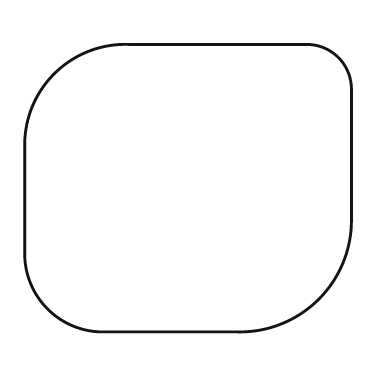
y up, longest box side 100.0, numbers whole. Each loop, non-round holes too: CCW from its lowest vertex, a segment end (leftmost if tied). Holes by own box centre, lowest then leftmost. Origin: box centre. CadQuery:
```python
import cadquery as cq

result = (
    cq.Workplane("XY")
    .moveTo(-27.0, -44.0)
    .lineTo(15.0, -44.0)
    .threePointArc((40.0, -34.0), (50.0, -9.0))
    .lineTo(50.0, 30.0)
    .threePointArc((46.0, 40.0), (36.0, 44.0))
    .lineTo(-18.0, 44.0)
    .threePointArc((-41.0, 35.0), (-50.0, 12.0))
    .lineTo(-50.0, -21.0)
    .threePointArc((-43.0, -37.0), (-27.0, -44.0))
    .close()
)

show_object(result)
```